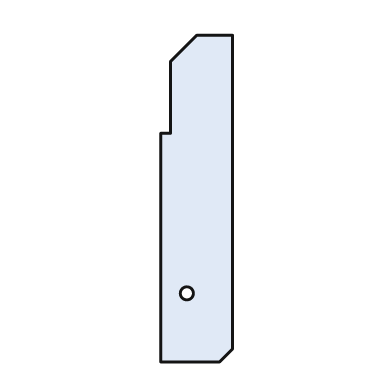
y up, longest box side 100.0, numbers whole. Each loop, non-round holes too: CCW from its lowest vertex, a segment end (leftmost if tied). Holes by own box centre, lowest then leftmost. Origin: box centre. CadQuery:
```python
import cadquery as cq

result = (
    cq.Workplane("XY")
    .moveTo(-11.0, -50.0)
    .lineTo(7.0, -50.0)
    .lineTo(11.0, -46.0)
    .lineTo(11.0, 50.0)
    .lineTo(0.0, 50.0)
    .lineTo(-8.0, 42.0)
    .lineTo(-8.0, 20.0)
    .lineTo(-11.0, 20.0)
    .close()
    .moveTo(-3.0, -29.0)
    .circle(2.0)
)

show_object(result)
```